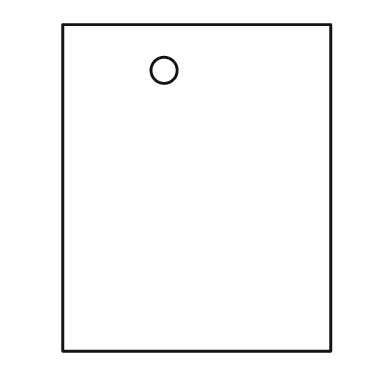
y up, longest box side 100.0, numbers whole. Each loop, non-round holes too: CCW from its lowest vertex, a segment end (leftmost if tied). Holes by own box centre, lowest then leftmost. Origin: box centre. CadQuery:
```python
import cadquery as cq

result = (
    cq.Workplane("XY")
    .moveTo(-41.0, -50.0)
    .lineTo(41.0, -50.0)
    .lineTo(41.0, 50.0)
    .lineTo(-41.0, 50.0)
    .close()
    .moveTo(-10.0, 36.0)
    .circle(4.0)
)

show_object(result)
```